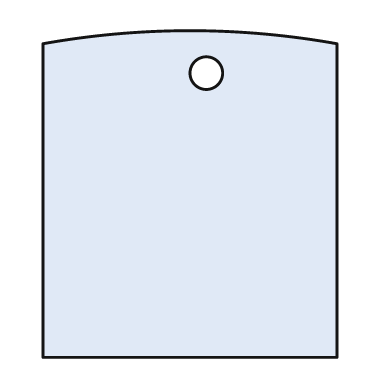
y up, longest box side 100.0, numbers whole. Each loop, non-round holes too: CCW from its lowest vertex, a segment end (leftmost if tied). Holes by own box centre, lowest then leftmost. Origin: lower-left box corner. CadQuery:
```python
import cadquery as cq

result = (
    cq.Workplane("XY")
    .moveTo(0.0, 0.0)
    .lineTo(90.0, 0.0)
    .lineTo(90.0, 96.0)
    .threePointArc((45.0, 100.0), (0.0, 96.0))
    .close()
    .moveTo(50.0, 87.0)
    .circle(5.0)
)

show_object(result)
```